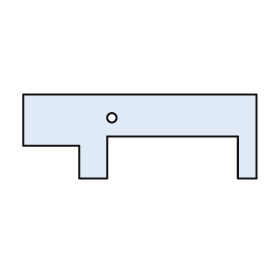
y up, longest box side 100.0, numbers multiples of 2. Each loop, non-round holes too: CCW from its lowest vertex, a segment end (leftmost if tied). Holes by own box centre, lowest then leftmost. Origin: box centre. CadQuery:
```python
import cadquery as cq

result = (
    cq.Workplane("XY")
    .moveTo(-26.0, -18.0)
    .lineTo(-14.0, -18.0)
    .lineTo(-14.0, 0.0)
    .lineTo(42.0, 0.0)
    .lineTo(42.0, -18.0)
    .lineTo(50.0, -18.0)
    .lineTo(50.0, 18.0)
    .lineTo(-50.0, 18.0)
    .lineTo(-50.0, -4.0)
    .lineTo(-26.0, -4.0)
    .close()
    .moveTo(-12.0, 8.0)
    .circle(2.0)
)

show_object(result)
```